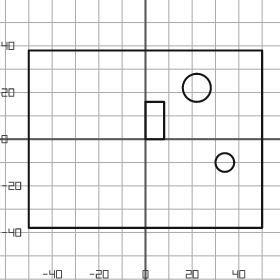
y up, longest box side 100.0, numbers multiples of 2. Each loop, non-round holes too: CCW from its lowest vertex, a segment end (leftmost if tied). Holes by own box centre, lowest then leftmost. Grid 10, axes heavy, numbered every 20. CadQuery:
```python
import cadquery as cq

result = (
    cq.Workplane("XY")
    .moveTo(-50.0, -38.0)
    .lineTo(50.0, -38.0)
    .lineTo(50.0, 38.0)
    .lineTo(-50.0, 38.0)
    .close()
    .moveTo(34.0, -10.0)
    .circle(4.0)
    .moveTo(0.0, 0.0)
    .lineTo(8.0, 0.0)
    .lineTo(8.0, 16.0)
    .lineTo(0.0, 16.0)
    .close()
    .moveTo(22.0, 22.0)
    .circle(6.0)
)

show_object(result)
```